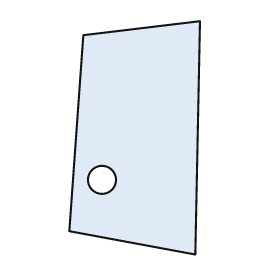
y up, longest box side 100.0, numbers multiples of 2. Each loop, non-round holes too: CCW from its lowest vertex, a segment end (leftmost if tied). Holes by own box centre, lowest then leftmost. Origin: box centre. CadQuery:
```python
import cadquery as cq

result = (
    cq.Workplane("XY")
    .moveTo(26.0, -50.0)
    .lineTo(28.0, 50.0)
    .lineTo(-22.0, 44.0)
    .lineTo(-28.0, -40.0)
    .close()
    .moveTo(-14.0, -18.0)
    .circle(6.0)
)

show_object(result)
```